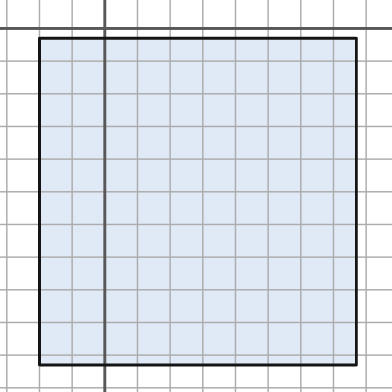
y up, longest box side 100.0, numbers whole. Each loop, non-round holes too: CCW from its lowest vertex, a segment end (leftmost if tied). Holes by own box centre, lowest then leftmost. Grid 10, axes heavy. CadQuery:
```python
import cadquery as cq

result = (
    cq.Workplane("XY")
    .moveTo(-20.0, -103.0)
    .lineTo(77.0, -103.0)
    .lineTo(77.0, -3.0)
    .lineTo(-20.0, -3.0)
    .close()
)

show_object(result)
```